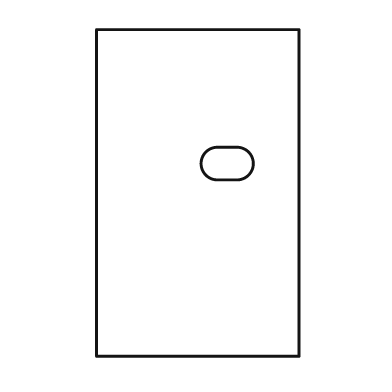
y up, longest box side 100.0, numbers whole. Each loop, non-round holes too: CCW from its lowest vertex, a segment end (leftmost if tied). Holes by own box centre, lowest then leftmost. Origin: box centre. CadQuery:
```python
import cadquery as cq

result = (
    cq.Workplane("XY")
    .moveTo(-31.0, -50.0)
    .lineTo(31.0, -50.0)
    .lineTo(31.0, 50.0)
    .lineTo(-31.0, 50.0)
    .close()
    .moveTo(6.0, 4.0)
    .lineTo(12.0, 4.0)
    .threePointArc((17.0, 9.0), (12.0, 14.0))
    .lineTo(6.0, 14.0)
    .threePointArc((1.0, 9.0), (6.0, 4.0))
    .close()
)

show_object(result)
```